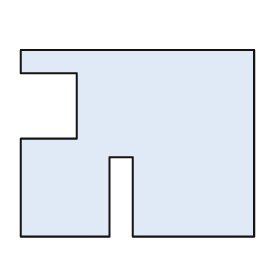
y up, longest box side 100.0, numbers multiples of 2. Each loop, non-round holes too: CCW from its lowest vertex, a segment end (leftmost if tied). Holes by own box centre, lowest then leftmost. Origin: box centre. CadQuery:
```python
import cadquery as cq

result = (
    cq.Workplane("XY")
    .moveTo(-50.0, -40.0)
    .lineTo(-12.0, -40.0)
    .lineTo(-12.0, -6.0)
    .lineTo(-2.0, -6.0)
    .lineTo(-2.0, -40.0)
    .lineTo(50.0, -40.0)
    .lineTo(50.0, 40.0)
    .lineTo(-50.0, 40.0)
    .lineTo(-50.0, 30.0)
    .lineTo(-26.0, 30.0)
    .lineTo(-26.0, 2.0)
    .lineTo(-50.0, 2.0)
    .close()
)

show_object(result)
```